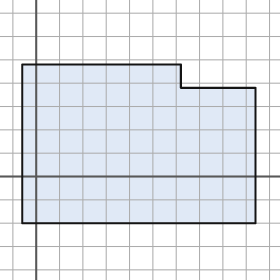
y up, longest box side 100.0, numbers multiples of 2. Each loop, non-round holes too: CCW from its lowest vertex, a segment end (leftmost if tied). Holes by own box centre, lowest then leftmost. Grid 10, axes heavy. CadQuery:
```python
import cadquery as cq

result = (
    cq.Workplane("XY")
    .moveTo(-6.0, -20.0)
    .lineTo(94.0, -20.0)
    .lineTo(94.0, 38.0)
    .lineTo(62.0, 38.0)
    .lineTo(62.0, 48.0)
    .lineTo(-6.0, 48.0)
    .close()
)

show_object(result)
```